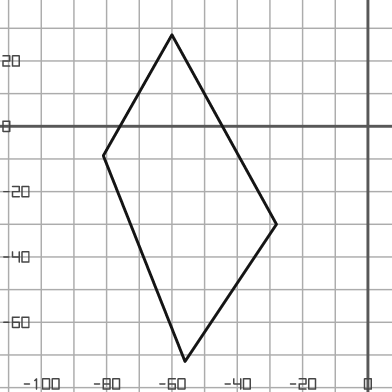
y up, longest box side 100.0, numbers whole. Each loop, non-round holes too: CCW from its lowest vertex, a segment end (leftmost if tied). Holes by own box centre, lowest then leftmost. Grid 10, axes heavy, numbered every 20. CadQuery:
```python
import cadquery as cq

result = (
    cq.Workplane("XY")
    .moveTo(-56.0, -72.0)
    .lineTo(-28.0, -30.0)
    .lineTo(-60.0, 28.0)
    .lineTo(-81.0, -9.0)
    .close()
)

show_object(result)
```